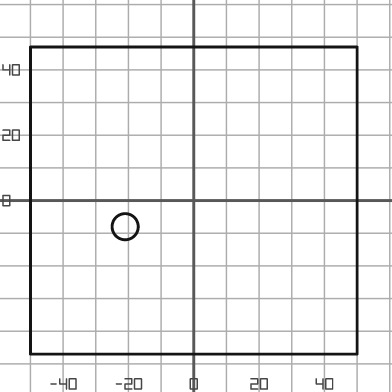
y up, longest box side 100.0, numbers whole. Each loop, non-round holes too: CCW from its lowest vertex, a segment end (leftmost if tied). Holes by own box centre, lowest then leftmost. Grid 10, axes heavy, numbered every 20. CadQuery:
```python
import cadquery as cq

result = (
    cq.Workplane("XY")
    .moveTo(-50.0, -47.0)
    .lineTo(50.0, -47.0)
    .lineTo(50.0, 47.0)
    .lineTo(-50.0, 47.0)
    .close()
    .moveTo(-21.0, -8.0)
    .circle(4.0)
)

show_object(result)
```